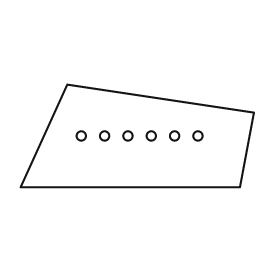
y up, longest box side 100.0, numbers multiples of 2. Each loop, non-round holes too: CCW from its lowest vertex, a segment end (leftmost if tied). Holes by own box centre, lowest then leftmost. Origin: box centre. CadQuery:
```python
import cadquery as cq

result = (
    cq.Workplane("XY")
    .moveTo(-50.0, -22.0)
    .lineTo(44.0, -22.0)
    .lineTo(50.0, 10.0)
    .lineTo(-30.0, 22.0)
    .close()
    .moveTo(-24.0, 0.0)
    .circle(2.0)
    .moveTo(-14.0, 0.0)
    .circle(2.0)
    .moveTo(-4.0, 0.0)
    .circle(2.0)
    .moveTo(6.0, 0.0)
    .circle(2.0)
    .moveTo(16.0, 0.0)
    .circle(2.0)
    .moveTo(26.0, 0.0)
    .circle(2.0)
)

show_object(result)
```